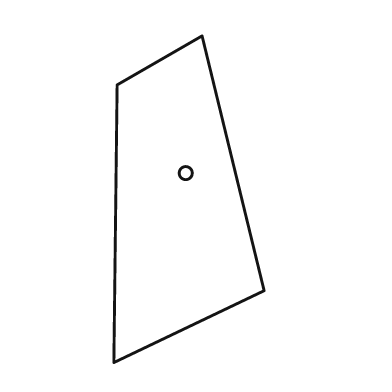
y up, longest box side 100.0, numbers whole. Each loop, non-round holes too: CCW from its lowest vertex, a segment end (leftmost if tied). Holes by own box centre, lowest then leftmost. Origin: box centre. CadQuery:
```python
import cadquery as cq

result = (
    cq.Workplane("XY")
    .moveTo(-23.0, -50.0)
    .lineTo(23.0, -28.0)
    .lineTo(4.0, 50.0)
    .lineTo(-22.0, 35.0)
    .close()
    .moveTo(-1.0, 8.0)
    .circle(2.0)
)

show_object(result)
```